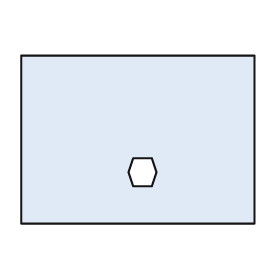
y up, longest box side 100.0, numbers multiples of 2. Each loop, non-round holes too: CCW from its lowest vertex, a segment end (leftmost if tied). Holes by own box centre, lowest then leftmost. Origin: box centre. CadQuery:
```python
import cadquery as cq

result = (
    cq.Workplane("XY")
    .moveTo(-50.0, -36.0)
    .lineTo(50.0, -36.0)
    .lineTo(50.0, 36.0)
    .lineTo(-50.0, 36.0)
    .close()
    .moveTo(-2.0, -20.0)
    .lineTo(6.0, -20.0)
    .lineTo(8.0, -14.0)
    .lineTo(6.0, -8.0)
    .lineTo(-2.0, -8.0)
    .lineTo(-4.0, -14.0)
    .close()
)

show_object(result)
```